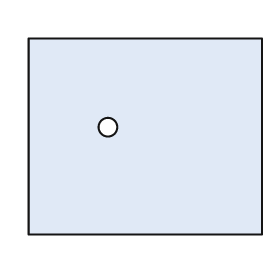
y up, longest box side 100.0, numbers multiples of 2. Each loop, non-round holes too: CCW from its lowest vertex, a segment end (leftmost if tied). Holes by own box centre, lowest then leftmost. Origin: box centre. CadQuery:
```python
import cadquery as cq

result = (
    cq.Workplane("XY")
    .moveTo(-50.0, -42.0)
    .lineTo(50.0, -42.0)
    .lineTo(50.0, 42.0)
    .lineTo(-50.0, 42.0)
    .close()
    .moveTo(-16.0, 4.0)
    .circle(4.0)
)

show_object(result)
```